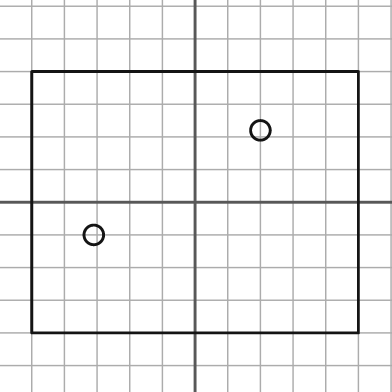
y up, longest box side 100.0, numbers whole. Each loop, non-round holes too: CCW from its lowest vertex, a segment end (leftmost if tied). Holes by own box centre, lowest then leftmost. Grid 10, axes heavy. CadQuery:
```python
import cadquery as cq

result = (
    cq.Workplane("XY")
    .moveTo(-50.0, -40.0)
    .lineTo(50.0, -40.0)
    .lineTo(50.0, 40.0)
    .lineTo(-50.0, 40.0)
    .close()
    .moveTo(-31.0, -10.0)
    .circle(3.0)
    .moveTo(20.0, 22.0)
    .circle(3.0)
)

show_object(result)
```